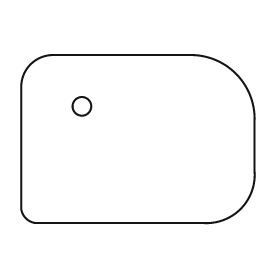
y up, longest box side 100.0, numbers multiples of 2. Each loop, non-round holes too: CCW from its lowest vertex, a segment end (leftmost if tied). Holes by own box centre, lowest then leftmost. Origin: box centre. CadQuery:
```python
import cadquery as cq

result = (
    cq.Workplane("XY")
    .moveTo(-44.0, -36.0)
    .lineTo(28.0, -36.0)
    .threePointArc((44.0, -30.0), (50.0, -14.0))
    .lineTo(50.0, 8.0)
    .threePointArc((42.0, 28.0), (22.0, 36.0))
    .lineTo(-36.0, 36.0)
    .threePointArc((-46.0, 32.0), (-50.0, 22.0))
    .lineTo(-50.0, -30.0)
    .threePointArc((-48.0, -34.0), (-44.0, -36.0))
    .close()
    .moveTo(-24.0, 14.0)
    .circle(4.0)
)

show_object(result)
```